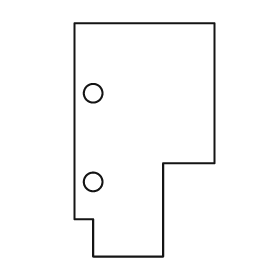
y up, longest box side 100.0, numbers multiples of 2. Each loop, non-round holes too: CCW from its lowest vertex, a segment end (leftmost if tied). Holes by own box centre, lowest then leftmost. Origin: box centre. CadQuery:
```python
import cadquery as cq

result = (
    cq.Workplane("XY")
    .moveTo(-22.0, -50.0)
    .lineTo(8.0, -50.0)
    .lineTo(8.0, -10.0)
    .lineTo(30.0, -10.0)
    .lineTo(30.0, 50.0)
    .lineTo(-30.0, 50.0)
    .lineTo(-30.0, -34.0)
    .lineTo(-22.0, -34.0)
    .close()
    .moveTo(-22.0, -18.0)
    .circle(4.0)
    .moveTo(-22.0, 20.0)
    .circle(4.0)
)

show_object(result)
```